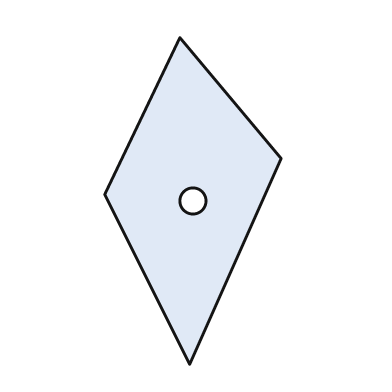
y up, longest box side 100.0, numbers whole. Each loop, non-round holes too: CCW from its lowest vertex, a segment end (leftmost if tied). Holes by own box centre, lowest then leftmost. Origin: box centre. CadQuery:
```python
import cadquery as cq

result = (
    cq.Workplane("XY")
    .moveTo(-1.0, -50.0)
    .lineTo(27.0, 13.0)
    .lineTo(-4.0, 50.0)
    .lineTo(-27.0, 2.0)
    .close()
    .moveTo(0.0, 0.0)
    .circle(4.0)
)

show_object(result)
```